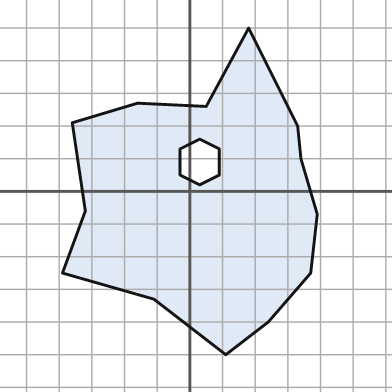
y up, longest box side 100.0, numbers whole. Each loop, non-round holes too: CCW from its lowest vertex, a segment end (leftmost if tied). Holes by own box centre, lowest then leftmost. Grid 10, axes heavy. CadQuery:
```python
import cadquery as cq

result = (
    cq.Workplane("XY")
    .moveTo(11.0, -50.0)
    .lineTo(24.0, -40.0)
    .lineTo(37.0, -25.0)
    .lineTo(39.0, -7.0)
    .lineTo(34.0, 10.0)
    .lineTo(33.0, 20.0)
    .lineTo(18.0, 50.0)
    .lineTo(5.0, 26.0)
    .lineTo(-16.0, 27.0)
    .lineTo(-36.0, 21.0)
    .lineTo(-32.0, -6.0)
    .lineTo(-39.0, -25.0)
    .lineTo(-11.0, -33.0)
    .close()
    .moveTo(3.0, 2.0)
    .lineTo(9.0, 5.0)
    .lineTo(9.0, 13.0)
    .lineTo(3.0, 16.0)
    .lineTo(-3.0, 13.0)
    .lineTo(-3.0, 5.0)
    .close()
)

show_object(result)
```